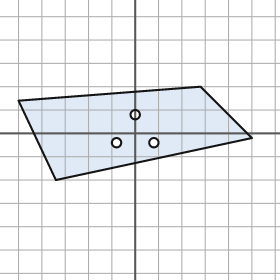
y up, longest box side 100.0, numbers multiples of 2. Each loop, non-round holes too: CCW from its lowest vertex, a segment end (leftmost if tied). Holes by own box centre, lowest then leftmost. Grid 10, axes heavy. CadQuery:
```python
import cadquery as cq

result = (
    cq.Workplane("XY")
    .moveTo(-34.0, -20.0)
    .lineTo(50.0, -2.0)
    .lineTo(28.0, 20.0)
    .lineTo(-50.0, 14.0)
    .close()
    .moveTo(-8.0, -4.0)
    .circle(2.0)
    .moveTo(8.0, -4.0)
    .circle(2.0)
    .moveTo(0.0, 8.0)
    .circle(2.0)
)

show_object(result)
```